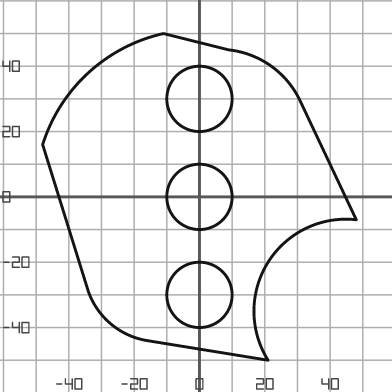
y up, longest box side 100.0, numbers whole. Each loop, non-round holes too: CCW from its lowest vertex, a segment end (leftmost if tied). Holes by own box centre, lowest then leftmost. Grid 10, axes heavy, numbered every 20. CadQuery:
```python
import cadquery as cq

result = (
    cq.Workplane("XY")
    .moveTo(21.0, -50.0)
    .threePointArc((21.0, -20.0), (48.0, -7.0))
    .lineTo(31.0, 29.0)
    .threePointArc((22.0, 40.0), (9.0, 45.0))
    .lineTo(-11.0, 50.0)
    .threePointArc((-34.0, 38.0), (-48.0, 16.0))
    .lineTo(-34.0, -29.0)
    .threePointArc((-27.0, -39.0), (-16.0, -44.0))
    .close()
    .moveTo(0.0, -30.0)
    .circle(10.0)
    .moveTo(0.0, 0.0)
    .circle(10.0)
    .moveTo(0.0, 30.0)
    .circle(10.0)
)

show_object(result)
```